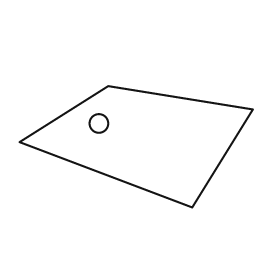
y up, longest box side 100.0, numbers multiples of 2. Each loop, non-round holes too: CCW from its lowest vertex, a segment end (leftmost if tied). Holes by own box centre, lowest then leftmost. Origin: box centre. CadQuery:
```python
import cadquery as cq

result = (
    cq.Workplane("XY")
    .moveTo(24.0, -26.0)
    .lineTo(50.0, 16.0)
    .lineTo(-12.0, 26.0)
    .lineTo(-50.0, 2.0)
    .close()
    .moveTo(-16.0, 10.0)
    .circle(4.0)
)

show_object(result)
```